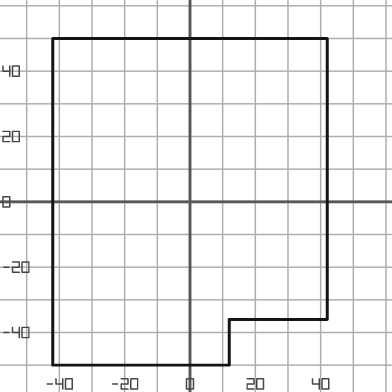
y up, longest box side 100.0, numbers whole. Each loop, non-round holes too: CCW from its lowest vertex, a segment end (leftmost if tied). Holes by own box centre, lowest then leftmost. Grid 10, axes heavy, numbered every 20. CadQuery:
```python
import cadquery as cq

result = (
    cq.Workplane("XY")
    .moveTo(-42.0, -50.0)
    .lineTo(12.0, -50.0)
    .lineTo(12.0, -36.0)
    .lineTo(42.0, -36.0)
    .lineTo(42.0, 50.0)
    .lineTo(-42.0, 50.0)
    .close()
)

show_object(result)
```